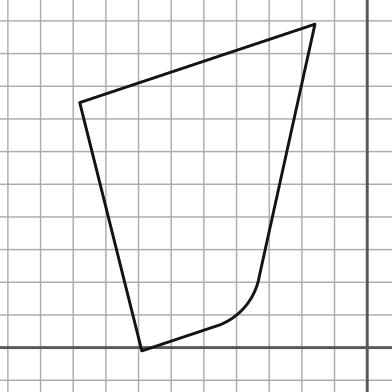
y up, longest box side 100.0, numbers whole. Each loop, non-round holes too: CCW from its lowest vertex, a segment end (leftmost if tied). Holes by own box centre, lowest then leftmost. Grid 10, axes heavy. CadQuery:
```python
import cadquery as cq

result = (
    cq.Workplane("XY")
    .moveTo(-69.0, -1.0)
    .lineTo(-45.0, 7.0)
    .threePointArc((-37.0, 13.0), (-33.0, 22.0))
    .lineTo(-16.0, 99.0)
    .lineTo(-88.0, 75.0)
    .close()
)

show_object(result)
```